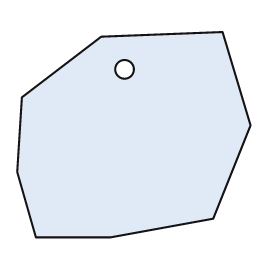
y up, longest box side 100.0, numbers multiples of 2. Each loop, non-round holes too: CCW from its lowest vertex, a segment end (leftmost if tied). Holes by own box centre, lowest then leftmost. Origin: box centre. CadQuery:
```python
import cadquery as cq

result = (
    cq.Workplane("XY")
    .moveTo(-42.0, -44.0)
    .lineTo(-10.0, -44.0)
    .lineTo(34.0, -36.0)
    .lineTo(50.0, 4.0)
    .lineTo(38.0, 44.0)
    .lineTo(-14.0, 42.0)
    .lineTo(-48.0, 16.0)
    .lineTo(-50.0, -16.0)
    .close()
    .moveTo(-4.0, 28.0)
    .circle(4.0)
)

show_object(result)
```